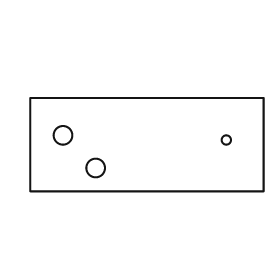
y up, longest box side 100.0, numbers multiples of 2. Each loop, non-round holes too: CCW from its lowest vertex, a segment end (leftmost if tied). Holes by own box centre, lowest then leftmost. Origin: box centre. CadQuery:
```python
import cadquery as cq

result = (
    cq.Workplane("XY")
    .moveTo(-50.0, -20.0)
    .lineTo(50.0, -20.0)
    .lineTo(50.0, 20.0)
    .lineTo(-50.0, 20.0)
    .close()
    .moveTo(-22.0, -10.0)
    .circle(4.0)
    .moveTo(34.0, 2.0)
    .circle(2.0)
    .moveTo(-36.0, 4.0)
    .circle(4.0)
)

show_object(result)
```